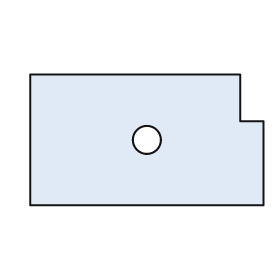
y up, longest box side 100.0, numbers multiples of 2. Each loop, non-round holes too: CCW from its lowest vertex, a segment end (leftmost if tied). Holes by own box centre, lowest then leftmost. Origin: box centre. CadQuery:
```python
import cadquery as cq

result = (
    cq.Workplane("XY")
    .moveTo(-50.0, -28.0)
    .lineTo(50.0, -28.0)
    .lineTo(50.0, 8.0)
    .lineTo(40.0, 8.0)
    .lineTo(40.0, 28.0)
    .lineTo(-50.0, 28.0)
    .close()
    .moveTo(0.0, 0.0)
    .circle(6.0)
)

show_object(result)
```